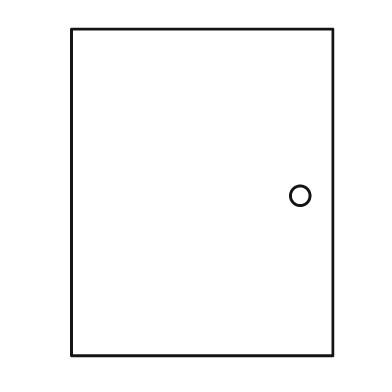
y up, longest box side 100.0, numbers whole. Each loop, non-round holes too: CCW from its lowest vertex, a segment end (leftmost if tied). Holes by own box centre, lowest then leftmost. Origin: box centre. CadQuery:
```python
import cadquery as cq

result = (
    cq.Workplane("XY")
    .moveTo(-40.0, -50.0)
    .lineTo(40.0, -50.0)
    .lineTo(40.0, 50.0)
    .lineTo(-40.0, 50.0)
    .close()
    .moveTo(30.0, -1.0)
    .circle(3.0)
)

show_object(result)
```